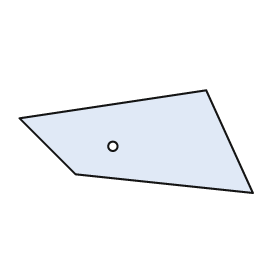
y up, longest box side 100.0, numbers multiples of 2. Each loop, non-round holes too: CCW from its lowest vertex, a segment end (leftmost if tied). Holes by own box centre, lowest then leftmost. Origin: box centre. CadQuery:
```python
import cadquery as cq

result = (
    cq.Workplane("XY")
    .moveTo(50.0, -22.0)
    .lineTo(30.0, 22.0)
    .lineTo(-50.0, 10.0)
    .lineTo(-26.0, -14.0)
    .close()
    .moveTo(-10.0, -2.0)
    .circle(2.0)
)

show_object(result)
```